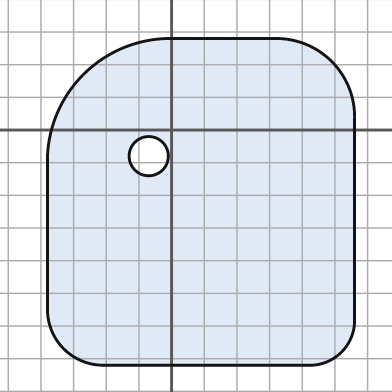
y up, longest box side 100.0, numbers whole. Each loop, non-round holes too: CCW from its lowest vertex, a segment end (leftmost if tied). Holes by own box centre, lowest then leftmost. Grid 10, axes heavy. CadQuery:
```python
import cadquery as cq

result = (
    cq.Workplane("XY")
    .moveTo(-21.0, -72.0)
    .lineTo(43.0, -72.0)
    .threePointArc((52.0, -68.0), (56.0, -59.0))
    .lineTo(56.0, 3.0)
    .threePointArc((49.0, 21.0), (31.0, 28.0))
    .lineTo(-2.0, 28.0)
    .threePointArc((-27.0, 17.0), (-38.0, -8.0))
    .lineTo(-38.0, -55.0)
    .threePointArc((-33.0, -67.0), (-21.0, -72.0))
    .close()
    .moveTo(-7.0, -8.0)
    .circle(6.0)
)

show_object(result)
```